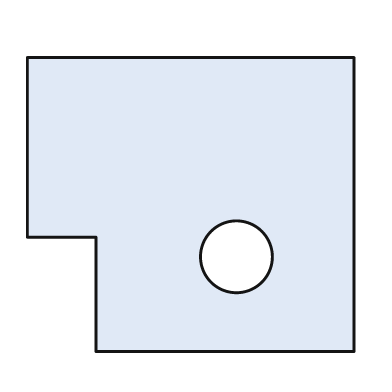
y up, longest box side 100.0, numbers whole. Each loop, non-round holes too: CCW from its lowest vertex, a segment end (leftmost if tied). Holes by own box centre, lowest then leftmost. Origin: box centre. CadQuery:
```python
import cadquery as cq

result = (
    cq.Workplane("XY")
    .moveTo(-29.0, -45.0)
    .lineTo(50.0, -45.0)
    .lineTo(50.0, 45.0)
    .lineTo(-50.0, 45.0)
    .lineTo(-50.0, -10.0)
    .lineTo(-29.0, -10.0)
    .close()
    .moveTo(14.0, -16.0)
    .circle(11.0)
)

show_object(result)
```